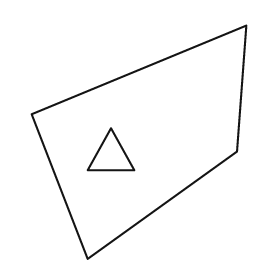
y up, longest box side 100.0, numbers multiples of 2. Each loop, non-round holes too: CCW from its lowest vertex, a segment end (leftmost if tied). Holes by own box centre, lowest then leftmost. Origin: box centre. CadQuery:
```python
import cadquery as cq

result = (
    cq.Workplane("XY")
    .moveTo(-22.0, -50.0)
    .lineTo(42.0, -4.0)
    .lineTo(46.0, 50.0)
    .lineTo(-46.0, 12.0)
    .close()
    .moveTo(-22.0, -12.0)
    .lineTo(-2.0, -12.0)
    .lineTo(-12.0, 6.0)
    .close()
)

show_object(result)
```